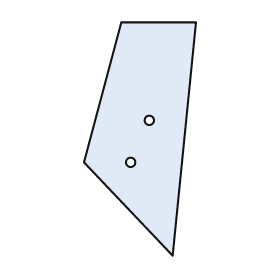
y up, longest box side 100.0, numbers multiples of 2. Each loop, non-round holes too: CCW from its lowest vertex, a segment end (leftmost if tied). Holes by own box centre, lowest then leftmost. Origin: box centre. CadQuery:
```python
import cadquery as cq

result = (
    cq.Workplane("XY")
    .moveTo(14.0, -50.0)
    .lineTo(24.0, 50.0)
    .lineTo(-8.0, 50.0)
    .lineTo(-24.0, -10.0)
    .close()
    .moveTo(-4.0, -10.0)
    .circle(2.0)
    .moveTo(4.0, 8.0)
    .circle(2.0)
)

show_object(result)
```